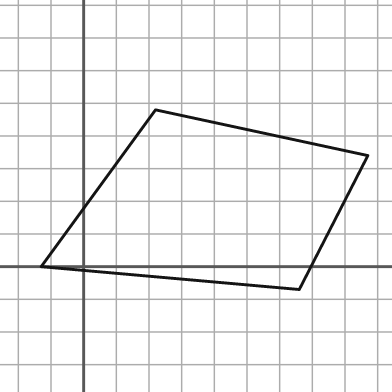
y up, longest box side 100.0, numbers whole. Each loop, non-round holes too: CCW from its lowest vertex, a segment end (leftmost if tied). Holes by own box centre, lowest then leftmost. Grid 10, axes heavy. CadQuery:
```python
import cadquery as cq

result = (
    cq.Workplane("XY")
    .moveTo(66.0, -7.0)
    .lineTo(87.0, 34.0)
    .lineTo(22.0, 48.0)
    .lineTo(-13.0, 0.0)
    .close()
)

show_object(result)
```